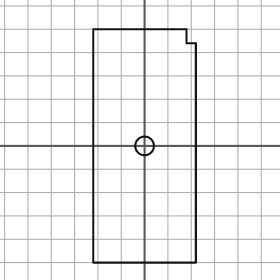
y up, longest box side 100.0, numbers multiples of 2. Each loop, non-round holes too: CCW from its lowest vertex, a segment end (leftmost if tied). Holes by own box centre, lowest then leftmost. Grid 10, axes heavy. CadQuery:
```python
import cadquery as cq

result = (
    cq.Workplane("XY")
    .moveTo(-22.0, -50.0)
    .lineTo(22.0, -50.0)
    .lineTo(22.0, 44.0)
    .lineTo(18.0, 44.0)
    .lineTo(18.0, 50.0)
    .lineTo(-22.0, 50.0)
    .close()
    .moveTo(0.0, 0.0)
    .circle(4.0)
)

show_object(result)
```